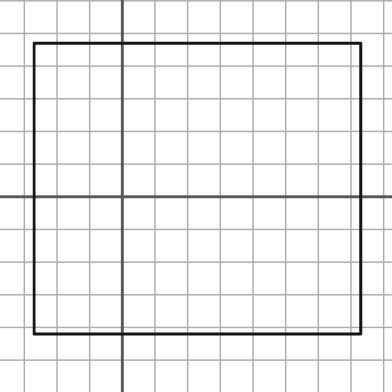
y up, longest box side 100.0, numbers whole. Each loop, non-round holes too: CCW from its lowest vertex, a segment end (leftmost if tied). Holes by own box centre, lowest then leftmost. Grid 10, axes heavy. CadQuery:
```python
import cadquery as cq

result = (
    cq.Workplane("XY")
    .moveTo(-27.0, -42.0)
    .lineTo(73.0, -42.0)
    .lineTo(73.0, 47.0)
    .lineTo(-27.0, 47.0)
    .close()
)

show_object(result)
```